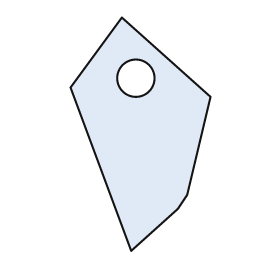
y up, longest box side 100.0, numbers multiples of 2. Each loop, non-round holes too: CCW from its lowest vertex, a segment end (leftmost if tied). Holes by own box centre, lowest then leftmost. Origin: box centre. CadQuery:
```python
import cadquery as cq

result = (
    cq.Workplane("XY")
    .moveTo(-4.0, -50.0)
    .lineTo(16.0, -32.0)
    .lineTo(20.0, -26.0)
    .lineTo(30.0, 16.0)
    .lineTo(-8.0, 50.0)
    .lineTo(-30.0, 20.0)
    .close()
    .moveTo(-2.0, 24.0)
    .circle(8.0)
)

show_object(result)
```